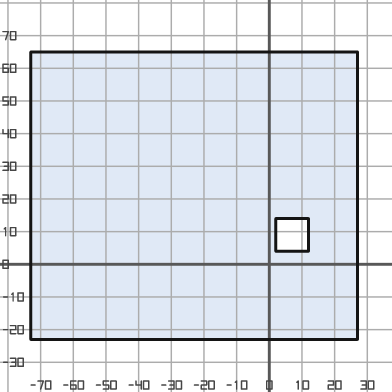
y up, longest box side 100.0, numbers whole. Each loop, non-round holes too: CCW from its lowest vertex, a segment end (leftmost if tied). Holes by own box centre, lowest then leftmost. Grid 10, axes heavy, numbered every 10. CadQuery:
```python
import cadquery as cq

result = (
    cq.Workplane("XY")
    .moveTo(-73.0, -23.0)
    .lineTo(27.0, -23.0)
    .lineTo(27.0, 65.0)
    .lineTo(-73.0, 65.0)
    .close()
    .moveTo(2.0, 4.0)
    .lineTo(12.0, 4.0)
    .lineTo(12.0, 14.0)
    .lineTo(2.0, 14.0)
    .close()
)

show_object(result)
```